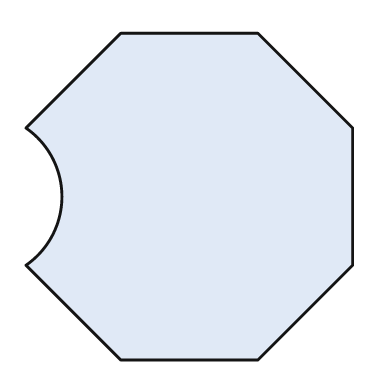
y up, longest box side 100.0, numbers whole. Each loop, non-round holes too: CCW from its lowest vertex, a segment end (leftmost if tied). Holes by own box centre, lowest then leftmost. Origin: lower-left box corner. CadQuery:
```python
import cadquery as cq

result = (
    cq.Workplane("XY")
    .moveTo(29.0, 0.0)
    .lineTo(71.0, 0.0)
    .lineTo(100.0, 29.0)
    .lineTo(100.0, 71.0)
    .lineTo(71.0, 100.0)
    .lineTo(29.0, 100.0)
    .lineTo(0.0, 71.0)
    .threePointArc((11.0, 50.0), (0.0, 29.0))
    .close()
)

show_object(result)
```